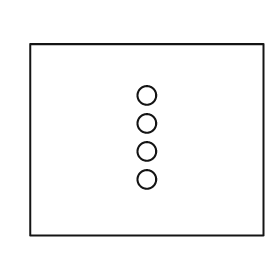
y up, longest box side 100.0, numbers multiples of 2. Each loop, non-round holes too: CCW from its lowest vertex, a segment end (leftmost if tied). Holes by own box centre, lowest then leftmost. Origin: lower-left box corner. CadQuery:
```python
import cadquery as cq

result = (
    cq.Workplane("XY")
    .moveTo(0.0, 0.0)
    .lineTo(100.0, 0.0)
    .lineTo(100.0, 82.0)
    .lineTo(0.0, 82.0)
    .close()
    .moveTo(50.0, 24.0)
    .circle(4.0)
    .moveTo(50.0, 36.0)
    .circle(4.0)
    .moveTo(50.0, 48.0)
    .circle(4.0)
    .moveTo(50.0, 60.0)
    .circle(4.0)
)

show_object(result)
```